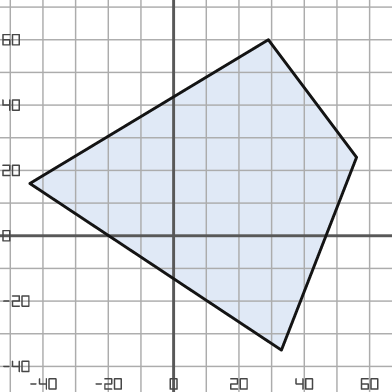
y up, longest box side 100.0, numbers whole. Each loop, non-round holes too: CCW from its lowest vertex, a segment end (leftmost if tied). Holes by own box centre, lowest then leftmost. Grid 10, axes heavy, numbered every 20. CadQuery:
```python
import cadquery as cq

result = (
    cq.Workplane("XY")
    .moveTo(33.0, -35.0)
    .lineTo(56.0, 24.0)
    .lineTo(29.0, 60.0)
    .lineTo(-44.0, 16.0)
    .close()
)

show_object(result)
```